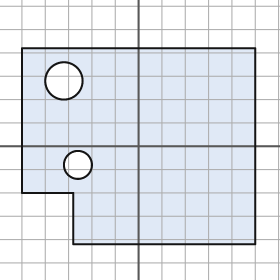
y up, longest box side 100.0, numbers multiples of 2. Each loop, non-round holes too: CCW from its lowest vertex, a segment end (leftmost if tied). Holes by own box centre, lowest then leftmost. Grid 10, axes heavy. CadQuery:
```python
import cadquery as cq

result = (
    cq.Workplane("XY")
    .moveTo(-28.0, -42.0)
    .lineTo(50.0, -42.0)
    .lineTo(50.0, 42.0)
    .lineTo(-50.0, 42.0)
    .lineTo(-50.0, -20.0)
    .lineTo(-28.0, -20.0)
    .close()
    .moveTo(-26.0, -8.0)
    .circle(6.0)
    .moveTo(-32.0, 28.0)
    .circle(8.0)
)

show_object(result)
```